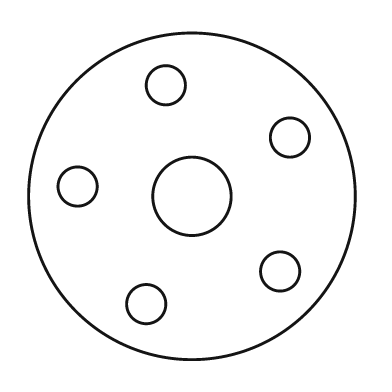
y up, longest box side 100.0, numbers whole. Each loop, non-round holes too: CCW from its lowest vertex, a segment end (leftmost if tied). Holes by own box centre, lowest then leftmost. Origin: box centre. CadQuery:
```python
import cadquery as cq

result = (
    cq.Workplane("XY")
    .moveTo(0.0, 0.0)
    .circle(50.0)
    .moveTo(-14.0, -33.0)
    .circle(6.0)
    .moveTo(27.0, -23.0)
    .circle(6.0)
    .moveTo(0.0, 0.0)
    .circle(12.0)
    .moveTo(-35.0, 3.0)
    .circle(6.0)
    .moveTo(30.0, 18.0)
    .circle(6.0)
    .moveTo(-8.0, 34.0)
    .circle(6.0)
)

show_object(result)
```